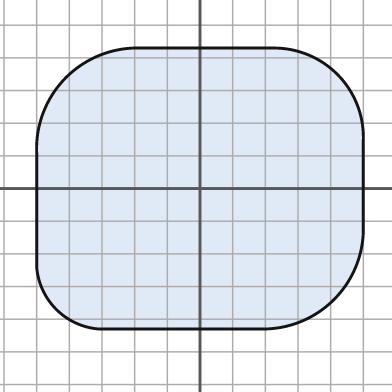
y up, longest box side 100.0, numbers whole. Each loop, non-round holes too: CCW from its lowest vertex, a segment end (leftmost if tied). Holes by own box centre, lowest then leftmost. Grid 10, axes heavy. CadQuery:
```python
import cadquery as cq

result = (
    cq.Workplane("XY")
    .moveTo(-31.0, -43.0)
    .lineTo(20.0, -43.0)
    .threePointArc((41.0, -34.0), (50.0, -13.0))
    .lineTo(50.0, 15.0)
    .threePointArc((42.0, 35.0), (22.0, 43.0))
    .lineTo(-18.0, 43.0)
    .threePointArc((-41.0, 34.0), (-50.0, 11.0))
    .lineTo(-50.0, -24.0)
    .threePointArc((-44.0, -37.0), (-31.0, -43.0))
    .close()
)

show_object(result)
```